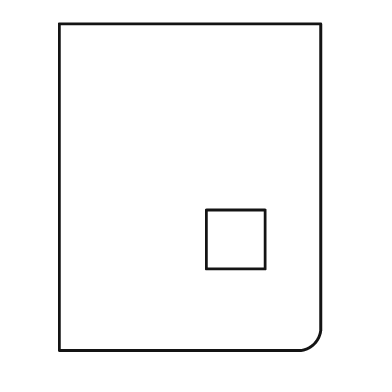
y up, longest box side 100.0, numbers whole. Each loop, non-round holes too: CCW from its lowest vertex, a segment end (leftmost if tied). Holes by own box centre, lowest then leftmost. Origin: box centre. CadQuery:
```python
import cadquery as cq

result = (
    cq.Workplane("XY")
    .moveTo(-40.0, -50.0)
    .lineTo(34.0, -50.0)
    .threePointArc((38.0, -48.0), (40.0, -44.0))
    .lineTo(40.0, 50.0)
    .lineTo(-40.0, 50.0)
    .close()
    .moveTo(5.0, -25.0)
    .lineTo(23.0, -25.0)
    .lineTo(23.0, -7.0)
    .lineTo(5.0, -7.0)
    .close()
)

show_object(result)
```